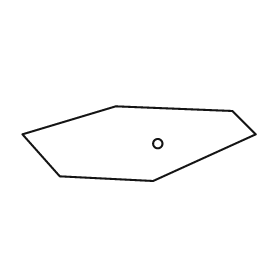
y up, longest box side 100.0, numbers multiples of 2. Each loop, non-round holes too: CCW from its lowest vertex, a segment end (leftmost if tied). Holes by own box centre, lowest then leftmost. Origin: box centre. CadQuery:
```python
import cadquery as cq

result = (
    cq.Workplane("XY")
    .moveTo(6.0, -16.0)
    .lineTo(50.0, 4.0)
    .lineTo(40.0, 14.0)
    .lineTo(-10.0, 16.0)
    .lineTo(-50.0, 4.0)
    .lineTo(-34.0, -14.0)
    .close()
    .moveTo(8.0, 0.0)
    .circle(2.0)
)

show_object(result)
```